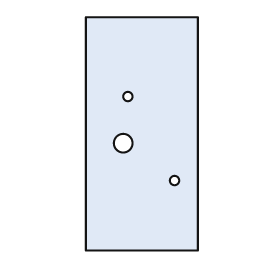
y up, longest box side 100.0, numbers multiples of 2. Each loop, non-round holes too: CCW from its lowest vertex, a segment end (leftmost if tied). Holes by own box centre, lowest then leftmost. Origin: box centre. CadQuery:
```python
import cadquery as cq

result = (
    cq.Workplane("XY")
    .moveTo(-24.0, -50.0)
    .lineTo(24.0, -50.0)
    .lineTo(24.0, 50.0)
    .lineTo(-24.0, 50.0)
    .close()
    .moveTo(14.0, -20.0)
    .circle(2.0)
    .moveTo(-8.0, -4.0)
    .circle(4.0)
    .moveTo(-6.0, 16.0)
    .circle(2.0)
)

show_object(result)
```